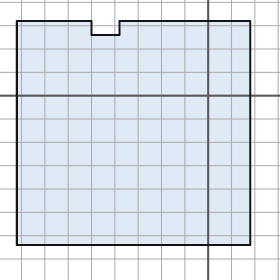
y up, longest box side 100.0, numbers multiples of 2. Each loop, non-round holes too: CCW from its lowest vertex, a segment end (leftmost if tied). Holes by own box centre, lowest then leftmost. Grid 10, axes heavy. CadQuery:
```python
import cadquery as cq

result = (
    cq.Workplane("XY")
    .moveTo(-82.0, -64.0)
    .lineTo(18.0, -64.0)
    .lineTo(18.0, 32.0)
    .lineTo(-38.0, 32.0)
    .lineTo(-38.0, 26.0)
    .lineTo(-50.0, 26.0)
    .lineTo(-50.0, 32.0)
    .lineTo(-82.0, 32.0)
    .close()
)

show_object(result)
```